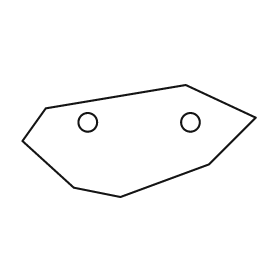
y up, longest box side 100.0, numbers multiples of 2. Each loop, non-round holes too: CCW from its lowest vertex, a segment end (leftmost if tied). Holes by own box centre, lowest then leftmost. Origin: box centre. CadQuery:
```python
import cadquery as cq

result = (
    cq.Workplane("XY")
    .moveTo(-8.0, -24.0)
    .lineTo(30.0, -10.0)
    .lineTo(50.0, 10.0)
    .lineTo(20.0, 24.0)
    .lineTo(-40.0, 14.0)
    .lineTo(-50.0, 0.0)
    .lineTo(-28.0, -20.0)
    .close()
    .moveTo(-22.0, 8.0)
    .circle(4.0)
    .moveTo(22.0, 8.0)
    .circle(4.0)
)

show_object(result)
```